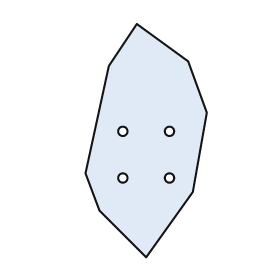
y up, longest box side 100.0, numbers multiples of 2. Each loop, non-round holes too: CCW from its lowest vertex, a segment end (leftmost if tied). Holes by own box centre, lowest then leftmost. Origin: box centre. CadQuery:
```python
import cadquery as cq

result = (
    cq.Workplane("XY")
    .moveTo(0.0, -50.0)
    .lineTo(20.0, -22.0)
    .lineTo(26.0, 12.0)
    .lineTo(18.0, 34.0)
    .lineTo(-4.0, 50.0)
    .lineTo(-16.0, 32.0)
    .lineTo(-26.0, -14.0)
    .lineTo(-20.0, -30.0)
    .close()
    .moveTo(-10.0, -16.0)
    .circle(2.0)
    .moveTo(10.0, -16.0)
    .circle(2.0)
    .moveTo(-10.0, 4.0)
    .circle(2.0)
    .moveTo(10.0, 4.0)
    .circle(2.0)
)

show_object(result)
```